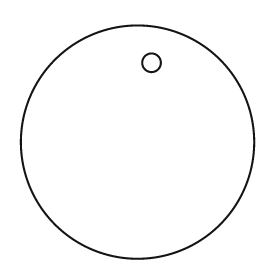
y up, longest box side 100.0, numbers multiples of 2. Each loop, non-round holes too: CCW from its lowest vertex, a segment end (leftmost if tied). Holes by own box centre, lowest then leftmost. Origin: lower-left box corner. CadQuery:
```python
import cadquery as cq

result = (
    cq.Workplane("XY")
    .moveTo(50.0, 50.0)
    .circle(50.0)
    .moveTo(56.0, 84.0)
    .circle(4.0)
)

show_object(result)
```